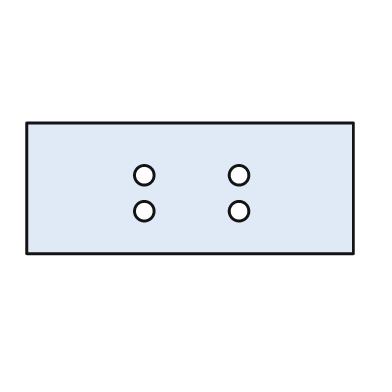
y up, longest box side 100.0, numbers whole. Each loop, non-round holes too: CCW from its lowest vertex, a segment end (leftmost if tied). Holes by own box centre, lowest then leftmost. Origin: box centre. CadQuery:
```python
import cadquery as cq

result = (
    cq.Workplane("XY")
    .moveTo(-50.0, -20.0)
    .lineTo(50.0, -20.0)
    .lineTo(50.0, 20.0)
    .lineTo(-50.0, 20.0)
    .close()
    .moveTo(-14.0, -7.0)
    .circle(3.0)
    .moveTo(15.0, -7.0)
    .circle(3.0)
    .moveTo(-14.0, 4.0)
    .circle(3.0)
    .moveTo(15.0, 4.0)
    .circle(3.0)
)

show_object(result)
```